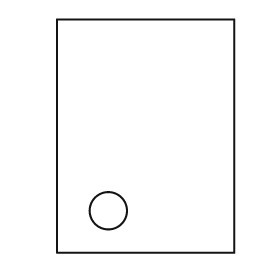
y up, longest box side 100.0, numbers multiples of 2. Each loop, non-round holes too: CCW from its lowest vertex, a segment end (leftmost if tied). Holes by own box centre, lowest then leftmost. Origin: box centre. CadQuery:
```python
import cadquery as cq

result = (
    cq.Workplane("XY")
    .moveTo(-38.0, -50.0)
    .lineTo(38.0, -50.0)
    .lineTo(38.0, 50.0)
    .lineTo(-38.0, 50.0)
    .close()
    .moveTo(-16.0, -32.0)
    .circle(8.0)
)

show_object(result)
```